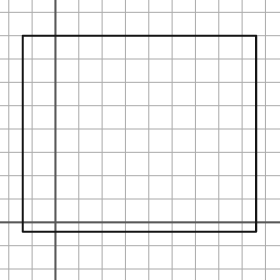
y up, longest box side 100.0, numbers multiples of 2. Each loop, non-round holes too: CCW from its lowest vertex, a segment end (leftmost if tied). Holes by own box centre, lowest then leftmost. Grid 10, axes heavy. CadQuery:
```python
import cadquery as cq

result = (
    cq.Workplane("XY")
    .moveTo(-14.0, -4.0)
    .lineTo(86.0, -4.0)
    .lineTo(86.0, 80.0)
    .lineTo(-14.0, 80.0)
    .close()
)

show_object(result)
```